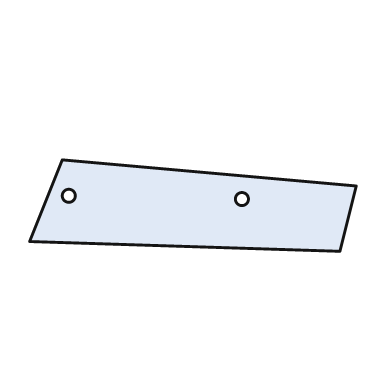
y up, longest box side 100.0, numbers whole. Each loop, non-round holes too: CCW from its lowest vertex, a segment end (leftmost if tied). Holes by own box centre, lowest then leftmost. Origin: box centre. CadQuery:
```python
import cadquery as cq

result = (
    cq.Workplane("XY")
    .moveTo(45.0, -14.0)
    .lineTo(50.0, 6.0)
    .lineTo(-40.0, 14.0)
    .lineTo(-50.0, -11.0)
    .close()
    .moveTo(15.0, 2.0)
    .circle(2.0)
    .moveTo(-38.0, 3.0)
    .circle(2.0)
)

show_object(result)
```